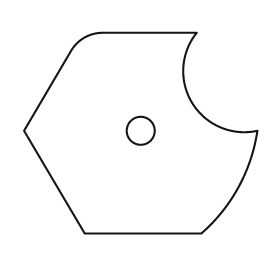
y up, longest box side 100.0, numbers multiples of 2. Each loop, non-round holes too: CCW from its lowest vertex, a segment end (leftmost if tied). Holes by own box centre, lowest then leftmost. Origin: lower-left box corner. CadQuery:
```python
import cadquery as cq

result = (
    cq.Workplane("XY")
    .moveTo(26.0, 0.0)
    .lineTo(76.0, 0.0)
    .threePointArc((92.0, 20.0), (100.0, 44.0))
    .threePointArc((72.0, 56.0), (74.0, 86.0))
    .lineTo(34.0, 86.0)
    .threePointArc((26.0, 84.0), (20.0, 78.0))
    .lineTo(0.0, 44.0)
    .close()
    .moveTo(50.0, 44.0)
    .circle(6.0)
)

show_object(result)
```